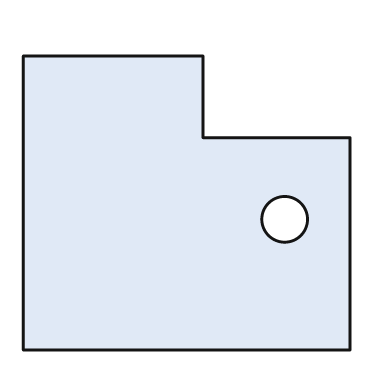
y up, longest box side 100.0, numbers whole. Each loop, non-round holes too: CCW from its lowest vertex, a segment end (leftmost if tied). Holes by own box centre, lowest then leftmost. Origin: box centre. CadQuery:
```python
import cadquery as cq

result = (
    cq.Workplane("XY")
    .moveTo(-50.0, -45.0)
    .lineTo(50.0, -45.0)
    .lineTo(50.0, 20.0)
    .lineTo(5.0, 20.0)
    .lineTo(5.0, 45.0)
    .lineTo(-50.0, 45.0)
    .close()
    .moveTo(30.0, -5.0)
    .circle(7.0)
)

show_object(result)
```